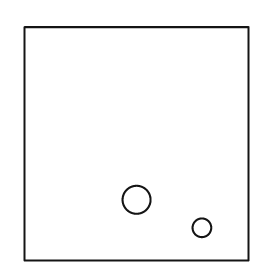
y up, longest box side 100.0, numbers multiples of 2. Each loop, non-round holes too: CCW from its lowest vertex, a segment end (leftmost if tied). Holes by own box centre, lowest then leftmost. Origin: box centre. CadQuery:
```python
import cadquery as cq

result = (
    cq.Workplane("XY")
    .moveTo(-48.0, -50.0)
    .lineTo(48.0, -50.0)
    .lineTo(48.0, 50.0)
    .lineTo(-48.0, 50.0)
    .close()
    .moveTo(28.0, -36.0)
    .circle(4.0)
    .moveTo(0.0, -24.0)
    .circle(6.0)
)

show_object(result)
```